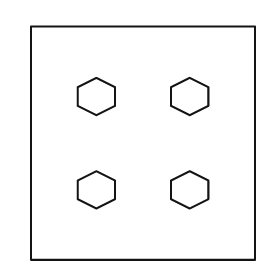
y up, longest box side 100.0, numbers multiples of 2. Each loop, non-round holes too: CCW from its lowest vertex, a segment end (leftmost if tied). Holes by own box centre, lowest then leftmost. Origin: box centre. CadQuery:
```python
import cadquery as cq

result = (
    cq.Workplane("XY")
    .moveTo(-48.0, -50.0)
    .lineTo(48.0, -50.0)
    .lineTo(48.0, 50.0)
    .lineTo(-48.0, 50.0)
    .close()
    .moveTo(-20.0, -28.0)
    .lineTo(-12.0, -24.0)
    .lineTo(-12.0, -16.0)
    .lineTo(-20.0, -12.0)
    .lineTo(-28.0, -16.0)
    .lineTo(-28.0, -24.0)
    .close()
    .moveTo(20.0, -28.0)
    .lineTo(28.0, -24.0)
    .lineTo(28.0, -16.0)
    .lineTo(20.0, -12.0)
    .lineTo(12.0, -16.0)
    .lineTo(12.0, -24.0)
    .close()
    .moveTo(-20.0, 12.0)
    .lineTo(-12.0, 16.0)
    .lineTo(-12.0, 24.0)
    .lineTo(-20.0, 28.0)
    .lineTo(-28.0, 24.0)
    .lineTo(-28.0, 16.0)
    .close()
    .moveTo(20.0, 12.0)
    .lineTo(28.0, 16.0)
    .lineTo(28.0, 24.0)
    .lineTo(20.0, 28.0)
    .lineTo(12.0, 24.0)
    .lineTo(12.0, 16.0)
    .close()
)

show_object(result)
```